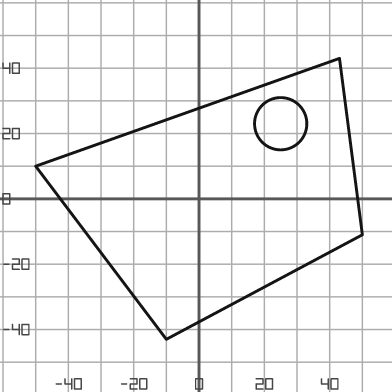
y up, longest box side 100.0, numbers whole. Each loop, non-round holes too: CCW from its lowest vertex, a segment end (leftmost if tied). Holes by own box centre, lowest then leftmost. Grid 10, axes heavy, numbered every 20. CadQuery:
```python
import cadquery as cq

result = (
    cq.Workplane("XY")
    .moveTo(-10.0, -43.0)
    .lineTo(50.0, -11.0)
    .lineTo(43.0, 43.0)
    .lineTo(-50.0, 10.0)
    .close()
    .moveTo(25.0, 23.0)
    .circle(8.0)
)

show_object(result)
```